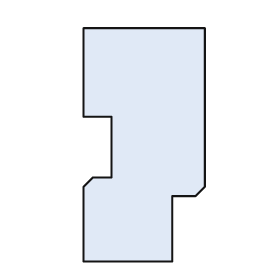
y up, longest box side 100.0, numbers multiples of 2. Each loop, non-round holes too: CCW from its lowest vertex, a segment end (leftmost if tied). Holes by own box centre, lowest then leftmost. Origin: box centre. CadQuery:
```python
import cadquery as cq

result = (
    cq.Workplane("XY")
    .moveTo(-26.0, -50.0)
    .lineTo(12.0, -50.0)
    .lineTo(12.0, -22.0)
    .lineTo(22.0, -22.0)
    .lineTo(26.0, -18.0)
    .lineTo(26.0, 50.0)
    .lineTo(-26.0, 50.0)
    .lineTo(-26.0, 12.0)
    .lineTo(-14.0, 12.0)
    .lineTo(-14.0, -14.0)
    .lineTo(-22.0, -14.0)
    .lineTo(-26.0, -18.0)
    .close()
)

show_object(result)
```